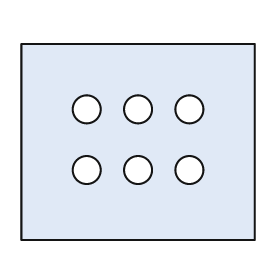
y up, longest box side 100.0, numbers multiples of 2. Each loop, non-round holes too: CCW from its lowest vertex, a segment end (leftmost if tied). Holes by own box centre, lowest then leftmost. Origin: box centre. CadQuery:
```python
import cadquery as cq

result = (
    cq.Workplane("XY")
    .moveTo(-50.0, -42.0)
    .lineTo(50.0, -42.0)
    .lineTo(50.0, 42.0)
    .lineTo(-50.0, 42.0)
    .close()
    .moveTo(-22.0, -12.0)
    .circle(6.0)
    .moveTo(0.0, -12.0)
    .circle(6.0)
    .moveTo(22.0, -12.0)
    .circle(6.0)
    .moveTo(-22.0, 14.0)
    .circle(6.0)
    .moveTo(0.0, 14.0)
    .circle(6.0)
    .moveTo(22.0, 14.0)
    .circle(6.0)
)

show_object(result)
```